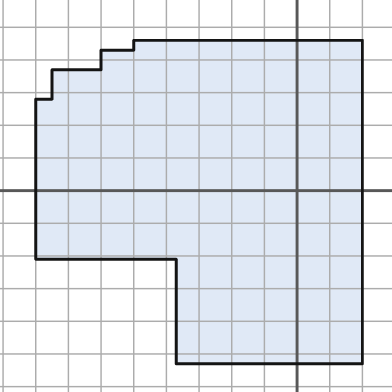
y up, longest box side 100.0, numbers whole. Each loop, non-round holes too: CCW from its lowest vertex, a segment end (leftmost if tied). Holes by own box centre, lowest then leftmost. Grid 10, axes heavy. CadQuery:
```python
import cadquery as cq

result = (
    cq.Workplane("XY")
    .moveTo(-37.0, -53.0)
    .lineTo(20.0, -53.0)
    .lineTo(20.0, 46.0)
    .lineTo(-50.0, 46.0)
    .lineTo(-50.0, 43.0)
    .lineTo(-60.0, 43.0)
    .lineTo(-60.0, 37.0)
    .lineTo(-75.0, 37.0)
    .lineTo(-75.0, 28.0)
    .lineTo(-80.0, 28.0)
    .lineTo(-80.0, -21.0)
    .lineTo(-37.0, -21.0)
    .close()
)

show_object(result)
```